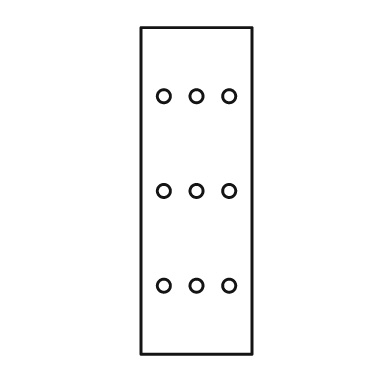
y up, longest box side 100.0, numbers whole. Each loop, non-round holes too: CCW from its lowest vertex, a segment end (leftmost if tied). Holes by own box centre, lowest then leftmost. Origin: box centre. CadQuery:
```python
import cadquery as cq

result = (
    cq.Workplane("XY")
    .moveTo(-17.0, -50.0)
    .lineTo(17.0, -50.0)
    .lineTo(17.0, 50.0)
    .lineTo(-17.0, 50.0)
    .close()
    .moveTo(-10.0, -29.0)
    .circle(2.0)
    .moveTo(0.0, -29.0)
    .circle(2.0)
    .moveTo(10.0, -29.0)
    .circle(2.0)
    .moveTo(-10.0, 0.0)
    .circle(2.0)
    .moveTo(0.0, 0.0)
    .circle(2.0)
    .moveTo(10.0, 0.0)
    .circle(2.0)
    .moveTo(-10.0, 29.0)
    .circle(2.0)
    .moveTo(0.0, 29.0)
    .circle(2.0)
    .moveTo(10.0, 29.0)
    .circle(2.0)
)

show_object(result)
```